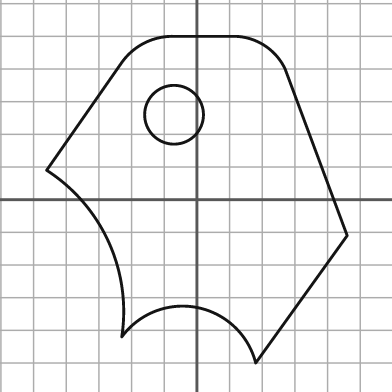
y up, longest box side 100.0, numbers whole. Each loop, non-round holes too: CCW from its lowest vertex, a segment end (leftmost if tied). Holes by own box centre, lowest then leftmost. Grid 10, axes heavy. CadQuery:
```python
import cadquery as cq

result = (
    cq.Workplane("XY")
    .moveTo(18.0, -50.0)
    .lineTo(46.0, -11.0)
    .lineTo(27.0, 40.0)
    .threePointArc((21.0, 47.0), (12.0, 50.0))
    .lineTo(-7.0, 50.0)
    .threePointArc((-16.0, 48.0), (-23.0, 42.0))
    .lineTo(-46.0, 9.0)
    .threePointArc((-27.0, -13.0), (-23.0, -42.0))
    .threePointArc((0.0, -33.0), (18.0, -50.0))
    .close()
    .moveTo(-7.0, 26.0)
    .circle(9.0)
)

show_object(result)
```